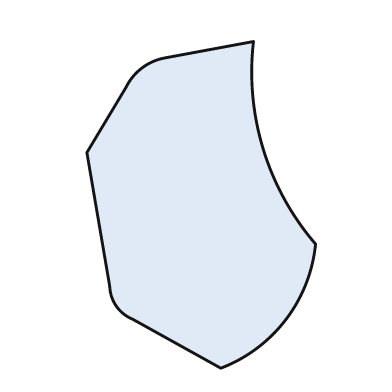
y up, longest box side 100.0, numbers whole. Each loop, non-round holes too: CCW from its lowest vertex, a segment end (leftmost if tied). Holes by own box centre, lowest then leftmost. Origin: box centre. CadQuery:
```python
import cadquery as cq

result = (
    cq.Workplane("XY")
    .moveTo(6.0, -50.0)
    .threePointArc((26.0, -35.0), (35.0, -12.0))
    .threePointArc((19.0, 17.0), (16.0, 50.0))
    .lineTo(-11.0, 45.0)
    .threePointArc((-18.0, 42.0), (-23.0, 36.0))
    .lineTo(-35.0, 16.0)
    .lineTo(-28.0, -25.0)
    .threePointArc((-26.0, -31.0), (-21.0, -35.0))
    .close()
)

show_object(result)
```